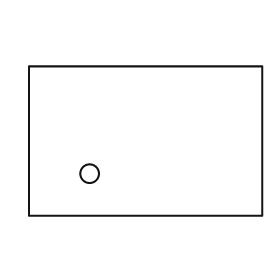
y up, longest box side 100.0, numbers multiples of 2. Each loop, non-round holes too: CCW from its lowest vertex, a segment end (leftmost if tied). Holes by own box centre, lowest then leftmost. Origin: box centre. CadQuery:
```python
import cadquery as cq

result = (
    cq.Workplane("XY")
    .moveTo(-50.0, -32.0)
    .lineTo(50.0, -32.0)
    .lineTo(50.0, 32.0)
    .lineTo(-50.0, 32.0)
    .close()
    .moveTo(-24.0, -14.0)
    .circle(4.0)
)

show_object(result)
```